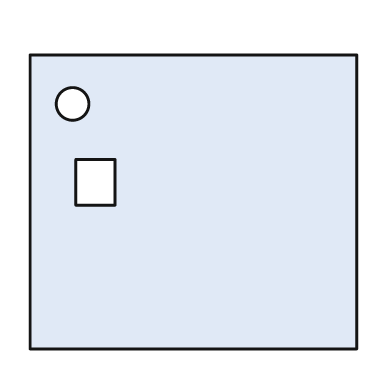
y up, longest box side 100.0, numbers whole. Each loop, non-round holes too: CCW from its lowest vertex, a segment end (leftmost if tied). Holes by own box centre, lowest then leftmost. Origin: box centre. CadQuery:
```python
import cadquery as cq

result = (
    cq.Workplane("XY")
    .moveTo(-50.0, -45.0)
    .lineTo(50.0, -45.0)
    .lineTo(50.0, 45.0)
    .lineTo(-50.0, 45.0)
    .close()
    .moveTo(-36.0, -1.0)
    .lineTo(-24.0, -1.0)
    .lineTo(-24.0, 13.0)
    .lineTo(-36.0, 13.0)
    .close()
    .moveTo(-37.0, 30.0)
    .circle(5.0)
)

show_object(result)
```